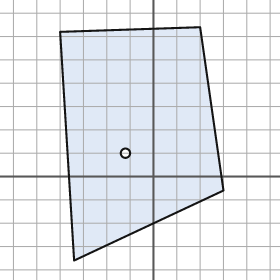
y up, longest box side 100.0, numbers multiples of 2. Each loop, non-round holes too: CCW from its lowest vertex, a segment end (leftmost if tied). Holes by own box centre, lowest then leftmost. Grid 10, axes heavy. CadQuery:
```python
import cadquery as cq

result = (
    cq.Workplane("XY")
    .moveTo(-34.0, -36.0)
    .lineTo(30.0, -6.0)
    .lineTo(20.0, 64.0)
    .lineTo(-40.0, 62.0)
    .close()
    .moveTo(-12.0, 10.0)
    .circle(2.0)
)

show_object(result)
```